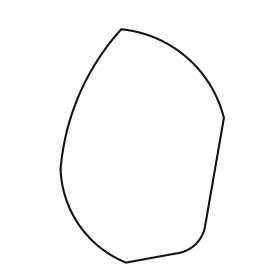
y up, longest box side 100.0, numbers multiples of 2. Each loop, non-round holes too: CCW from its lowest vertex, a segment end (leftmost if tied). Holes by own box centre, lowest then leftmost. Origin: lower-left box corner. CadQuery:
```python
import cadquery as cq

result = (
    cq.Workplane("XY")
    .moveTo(28.0, 0.0)
    .lineTo(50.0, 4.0)
    .threePointArc((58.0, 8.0), (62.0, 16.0))
    .lineTo(70.0, 62.0)
    .threePointArc((54.0, 88.0), (26.0, 100.0))
    .threePointArc((8.0, 72.0), (0.0, 40.0))
    .threePointArc((8.0, 16.0), (28.0, 0.0))
    .close()
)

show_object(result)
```